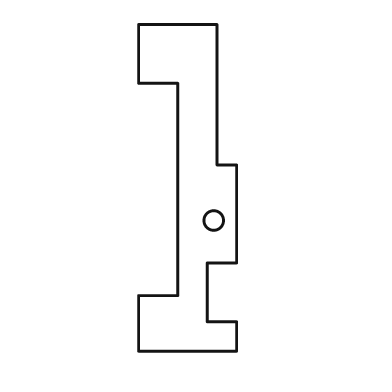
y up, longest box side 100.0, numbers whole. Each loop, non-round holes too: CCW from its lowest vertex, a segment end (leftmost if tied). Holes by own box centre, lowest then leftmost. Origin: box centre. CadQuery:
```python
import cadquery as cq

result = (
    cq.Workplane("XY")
    .moveTo(-15.0, -50.0)
    .lineTo(15.0, -50.0)
    .lineTo(15.0, -41.0)
    .lineTo(6.0, -41.0)
    .lineTo(6.0, -23.0)
    .lineTo(15.0, -23.0)
    .lineTo(15.0, 7.0)
    .lineTo(9.0, 7.0)
    .lineTo(9.0, 50.0)
    .lineTo(-15.0, 50.0)
    .lineTo(-15.0, 32.0)
    .lineTo(-3.0, 32.0)
    .lineTo(-3.0, -33.0)
    .lineTo(-15.0, -33.0)
    .close()
    .moveTo(8.0, -10.0)
    .circle(3.0)
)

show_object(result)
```